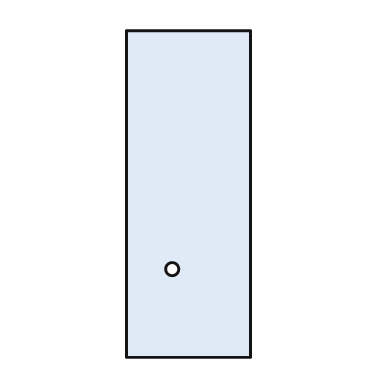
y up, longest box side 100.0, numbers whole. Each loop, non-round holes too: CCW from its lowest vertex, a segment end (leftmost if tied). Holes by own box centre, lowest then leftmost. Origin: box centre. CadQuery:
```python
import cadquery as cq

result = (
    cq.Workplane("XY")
    .moveTo(-19.0, -50.0)
    .lineTo(19.0, -50.0)
    .lineTo(19.0, 50.0)
    .lineTo(-19.0, 50.0)
    .close()
    .moveTo(-5.0, -23.0)
    .circle(2.0)
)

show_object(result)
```